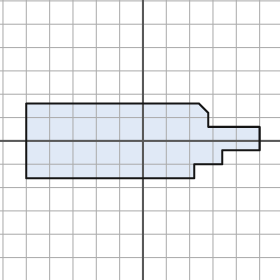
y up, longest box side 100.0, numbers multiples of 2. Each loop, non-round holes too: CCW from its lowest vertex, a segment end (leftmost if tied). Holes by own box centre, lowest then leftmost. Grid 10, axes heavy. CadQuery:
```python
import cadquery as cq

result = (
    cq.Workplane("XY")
    .moveTo(-50.0, -16.0)
    .lineTo(22.0, -16.0)
    .lineTo(22.0, -10.0)
    .lineTo(34.0, -10.0)
    .lineTo(34.0, -4.0)
    .lineTo(50.0, -4.0)
    .lineTo(50.0, 6.0)
    .lineTo(28.0, 6.0)
    .lineTo(28.0, 12.0)
    .lineTo(24.0, 16.0)
    .lineTo(-50.0, 16.0)
    .close()
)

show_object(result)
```